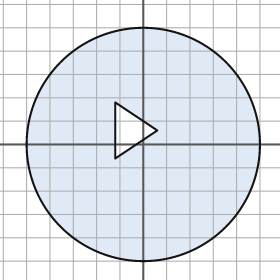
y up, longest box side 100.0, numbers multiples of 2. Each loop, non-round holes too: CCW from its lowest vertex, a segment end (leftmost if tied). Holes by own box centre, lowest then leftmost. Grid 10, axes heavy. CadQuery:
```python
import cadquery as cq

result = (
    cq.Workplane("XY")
    .moveTo(0.0, 0.0)
    .circle(50.0)
    .moveTo(-12.0, -6.0)
    .lineTo(6.0, 6.0)
    .lineTo(-12.0, 18.0)
    .close()
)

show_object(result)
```